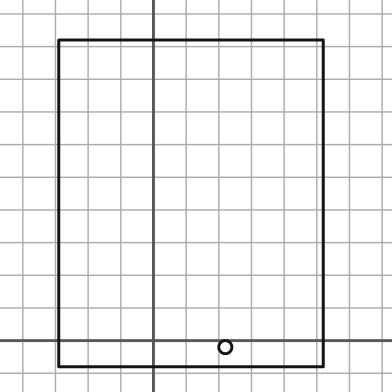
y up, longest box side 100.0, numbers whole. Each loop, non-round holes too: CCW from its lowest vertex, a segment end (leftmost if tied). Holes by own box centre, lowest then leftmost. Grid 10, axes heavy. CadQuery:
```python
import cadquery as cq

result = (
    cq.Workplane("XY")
    .moveTo(-29.0, -8.0)
    .lineTo(52.0, -8.0)
    .lineTo(52.0, 92.0)
    .lineTo(-29.0, 92.0)
    .close()
    .moveTo(22.0, -2.0)
    .circle(2.0)
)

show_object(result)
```